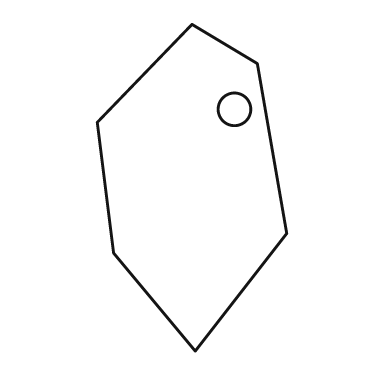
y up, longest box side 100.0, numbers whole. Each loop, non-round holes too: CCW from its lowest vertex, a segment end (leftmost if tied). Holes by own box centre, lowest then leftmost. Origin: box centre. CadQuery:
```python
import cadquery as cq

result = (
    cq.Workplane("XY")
    .moveTo(1.0, -50.0)
    .lineTo(29.0, -14.0)
    .lineTo(20.0, 38.0)
    .lineTo(0.0, 50.0)
    .lineTo(-29.0, 20.0)
    .lineTo(-24.0, -20.0)
    .close()
    .moveTo(13.0, 24.0)
    .circle(5.0)
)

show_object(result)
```